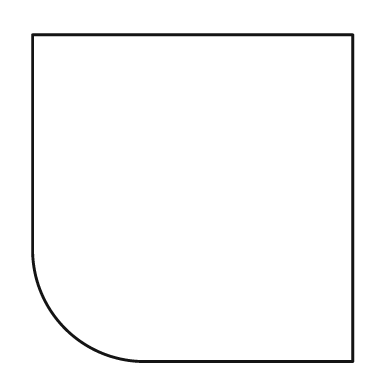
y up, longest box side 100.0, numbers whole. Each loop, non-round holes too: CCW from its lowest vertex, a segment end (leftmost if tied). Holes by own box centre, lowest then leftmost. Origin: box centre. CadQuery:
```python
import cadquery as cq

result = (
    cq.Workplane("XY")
    .moveTo(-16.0, -50.0)
    .lineTo(49.0, -50.0)
    .lineTo(49.0, 50.0)
    .lineTo(-49.0, 50.0)
    .lineTo(-49.0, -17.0)
    .threePointArc((-39.0, -40.0), (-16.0, -50.0))
    .close()
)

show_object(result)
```